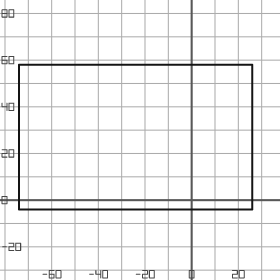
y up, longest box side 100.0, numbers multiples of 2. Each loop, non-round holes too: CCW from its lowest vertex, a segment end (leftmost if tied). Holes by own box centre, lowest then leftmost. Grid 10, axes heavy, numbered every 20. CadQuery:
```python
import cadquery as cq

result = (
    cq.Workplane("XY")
    .moveTo(-74.0, -4.0)
    .lineTo(26.0, -4.0)
    .lineTo(26.0, 58.0)
    .lineTo(-74.0, 58.0)
    .close()
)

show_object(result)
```